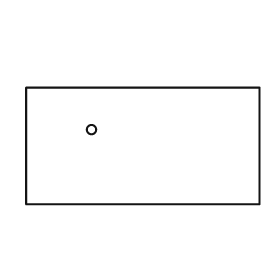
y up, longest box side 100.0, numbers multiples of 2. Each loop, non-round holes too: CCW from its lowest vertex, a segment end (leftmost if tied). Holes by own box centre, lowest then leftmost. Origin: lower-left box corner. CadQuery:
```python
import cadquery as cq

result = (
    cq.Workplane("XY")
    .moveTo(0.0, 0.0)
    .lineTo(100.0, 0.0)
    .lineTo(100.0, 50.0)
    .lineTo(0.0, 50.0)
    .close()
    .moveTo(28.0, 32.0)
    .circle(2.0)
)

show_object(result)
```